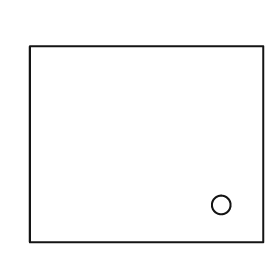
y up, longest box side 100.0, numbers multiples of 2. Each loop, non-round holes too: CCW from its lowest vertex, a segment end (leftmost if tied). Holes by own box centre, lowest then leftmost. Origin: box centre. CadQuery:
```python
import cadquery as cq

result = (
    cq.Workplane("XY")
    .moveTo(-50.0, -42.0)
    .lineTo(50.0, -42.0)
    .lineTo(50.0, 42.0)
    .lineTo(-50.0, 42.0)
    .close()
    .moveTo(32.0, -26.0)
    .circle(4.0)
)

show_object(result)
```